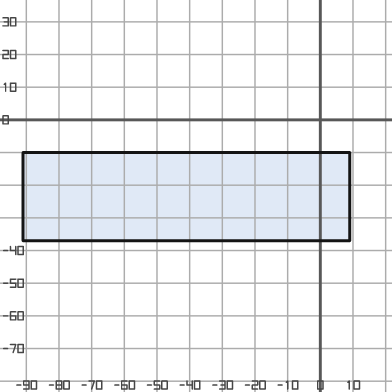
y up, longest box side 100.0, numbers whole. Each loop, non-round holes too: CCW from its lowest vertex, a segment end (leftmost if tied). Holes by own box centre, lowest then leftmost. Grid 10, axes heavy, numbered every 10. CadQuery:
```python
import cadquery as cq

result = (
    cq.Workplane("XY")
    .moveTo(-91.0, -37.0)
    .lineTo(9.0, -37.0)
    .lineTo(9.0, -10.0)
    .lineTo(-91.0, -10.0)
    .close()
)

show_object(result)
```